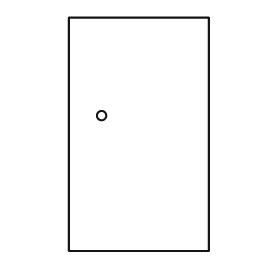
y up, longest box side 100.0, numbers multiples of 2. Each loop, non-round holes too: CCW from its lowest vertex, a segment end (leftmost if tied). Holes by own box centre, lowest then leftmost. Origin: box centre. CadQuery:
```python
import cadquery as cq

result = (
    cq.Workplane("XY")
    .moveTo(-30.0, -50.0)
    .lineTo(30.0, -50.0)
    .lineTo(30.0, 50.0)
    .lineTo(-30.0, 50.0)
    .close()
    .moveTo(-16.0, 8.0)
    .circle(2.0)
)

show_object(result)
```